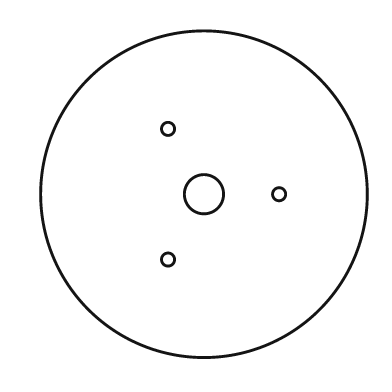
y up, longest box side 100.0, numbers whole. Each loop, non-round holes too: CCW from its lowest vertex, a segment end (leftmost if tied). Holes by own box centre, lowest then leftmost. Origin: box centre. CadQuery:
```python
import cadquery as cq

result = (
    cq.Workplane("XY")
    .moveTo(0.0, 0.0)
    .circle(50.0)
    .moveTo(-11.0, -20.0)
    .circle(2.0)
    .moveTo(0.0, 0.0)
    .circle(6.0)
    .moveTo(23.0, 0.0)
    .circle(2.0)
    .moveTo(-11.0, 20.0)
    .circle(2.0)
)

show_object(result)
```